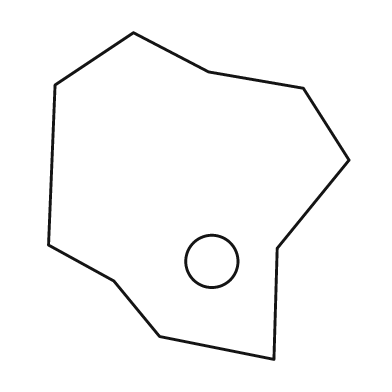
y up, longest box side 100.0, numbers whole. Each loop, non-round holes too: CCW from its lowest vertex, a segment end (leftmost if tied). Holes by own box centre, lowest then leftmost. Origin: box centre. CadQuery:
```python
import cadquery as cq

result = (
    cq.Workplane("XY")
    .moveTo(23.0, -50.0)
    .lineTo(24.0, -16.0)
    .lineTo(46.0, 11.0)
    .lineTo(32.0, 33.0)
    .lineTo(3.0, 38.0)
    .lineTo(-20.0, 50.0)
    .lineTo(-44.0, 34.0)
    .lineTo(-46.0, -15.0)
    .lineTo(-26.0, -26.0)
    .lineTo(-12.0, -43.0)
    .close()
    .moveTo(4.0, -20.0)
    .circle(8.0)
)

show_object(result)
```